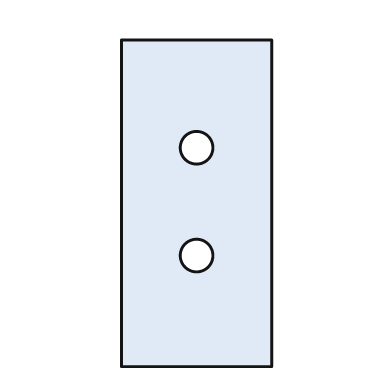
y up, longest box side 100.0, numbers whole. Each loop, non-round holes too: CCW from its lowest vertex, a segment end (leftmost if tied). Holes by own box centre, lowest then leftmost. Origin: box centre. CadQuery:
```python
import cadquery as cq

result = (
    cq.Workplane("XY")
    .moveTo(-23.0, -50.0)
    .lineTo(23.0, -50.0)
    .lineTo(23.0, 50.0)
    .lineTo(-23.0, 50.0)
    .close()
    .moveTo(0.0, -16.0)
    .circle(5.0)
    .moveTo(0.0, 17.0)
    .circle(5.0)
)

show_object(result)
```